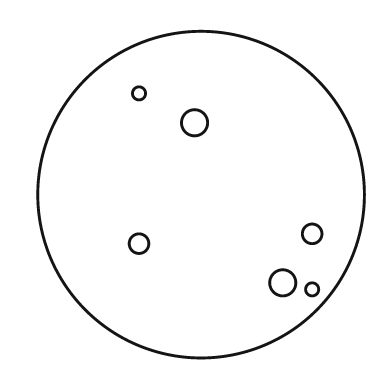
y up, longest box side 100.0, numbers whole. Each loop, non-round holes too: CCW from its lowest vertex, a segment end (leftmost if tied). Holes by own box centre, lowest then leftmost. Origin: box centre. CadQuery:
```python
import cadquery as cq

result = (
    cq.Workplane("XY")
    .moveTo(0.0, 0.0)
    .circle(50.0)
    .moveTo(34.0, -29.0)
    .circle(2.0)
    .moveTo(25.0, -27.0)
    .circle(4.0)
    .moveTo(-19.0, -15.0)
    .circle(3.0)
    .moveTo(34.0, -12.0)
    .circle(3.0)
    .moveTo(-2.0, 22.0)
    .circle(4.0)
    .moveTo(-19.0, 31.0)
    .circle(2.0)
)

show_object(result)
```